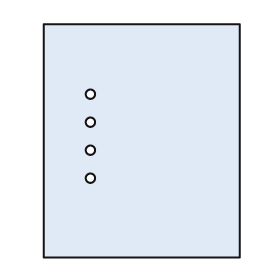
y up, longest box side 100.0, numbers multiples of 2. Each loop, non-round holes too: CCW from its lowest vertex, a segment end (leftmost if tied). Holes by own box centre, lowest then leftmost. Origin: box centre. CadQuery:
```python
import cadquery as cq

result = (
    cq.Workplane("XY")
    .moveTo(-42.0, -50.0)
    .lineTo(42.0, -50.0)
    .lineTo(42.0, 50.0)
    .lineTo(-42.0, 50.0)
    .close()
    .moveTo(-22.0, -16.0)
    .circle(2.0)
    .moveTo(-22.0, -4.0)
    .circle(2.0)
    .moveTo(-22.0, 8.0)
    .circle(2.0)
    .moveTo(-22.0, 20.0)
    .circle(2.0)
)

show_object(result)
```